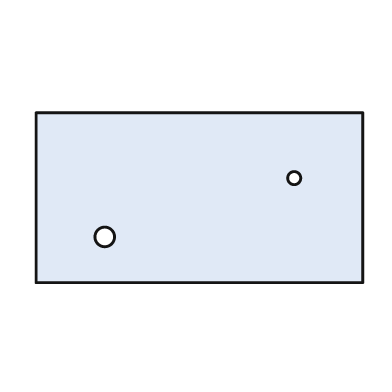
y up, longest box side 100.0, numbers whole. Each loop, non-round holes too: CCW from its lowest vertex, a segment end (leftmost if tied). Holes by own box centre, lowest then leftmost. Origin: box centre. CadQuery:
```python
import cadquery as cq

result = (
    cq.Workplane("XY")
    .moveTo(-50.0, -26.0)
    .lineTo(50.0, -26.0)
    .lineTo(50.0, 26.0)
    .lineTo(-50.0, 26.0)
    .close()
    .moveTo(-29.0, -12.0)
    .circle(3.0)
    .moveTo(29.0, 6.0)
    .circle(2.0)
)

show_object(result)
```